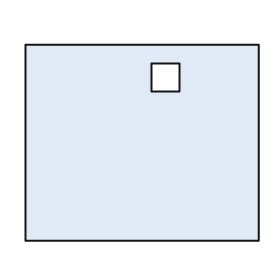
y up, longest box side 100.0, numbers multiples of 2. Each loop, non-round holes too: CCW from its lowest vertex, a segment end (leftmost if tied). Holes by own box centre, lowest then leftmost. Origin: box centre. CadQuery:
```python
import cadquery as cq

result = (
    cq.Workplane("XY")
    .moveTo(-50.0, -42.0)
    .lineTo(50.0, -42.0)
    .lineTo(50.0, 42.0)
    .lineTo(-50.0, 42.0)
    .close()
    .moveTo(4.0, 22.0)
    .lineTo(16.0, 22.0)
    .lineTo(16.0, 34.0)
    .lineTo(4.0, 34.0)
    .close()
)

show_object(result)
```